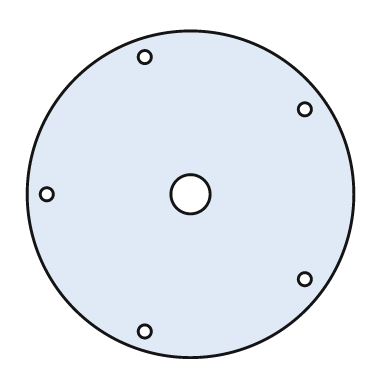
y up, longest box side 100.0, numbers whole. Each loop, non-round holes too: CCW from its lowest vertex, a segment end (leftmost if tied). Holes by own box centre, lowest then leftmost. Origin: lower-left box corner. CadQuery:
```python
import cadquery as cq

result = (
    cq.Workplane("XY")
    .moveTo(50.0, 50.0)
    .circle(50.0)
    .moveTo(36.0, 8.0)
    .circle(2.0)
    .moveTo(85.0, 24.0)
    .circle(2.0)
    .moveTo(6.0, 50.0)
    .circle(2.0)
    .moveTo(50.0, 50.0)
    .circle(6.0)
    .moveTo(85.0, 76.0)
    .circle(2.0)
    .moveTo(36.0, 92.0)
    .circle(2.0)
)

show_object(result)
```